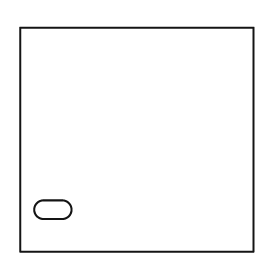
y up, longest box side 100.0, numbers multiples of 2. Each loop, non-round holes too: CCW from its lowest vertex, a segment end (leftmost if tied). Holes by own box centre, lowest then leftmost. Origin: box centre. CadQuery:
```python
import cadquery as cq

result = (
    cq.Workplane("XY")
    .moveTo(-50.0, -48.0)
    .lineTo(50.0, -48.0)
    .lineTo(50.0, 48.0)
    .lineTo(-50.0, 48.0)
    .close()
    .moveTo(-40.0, -34.0)
    .lineTo(-32.0, -34.0)
    .threePointArc((-28.0, -30.0), (-32.0, -26.0))
    .lineTo(-40.0, -26.0)
    .threePointArc((-44.0, -30.0), (-40.0, -34.0))
    .close()
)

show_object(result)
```